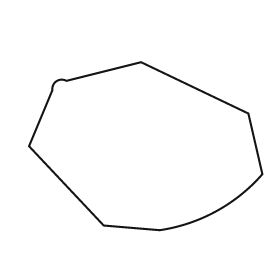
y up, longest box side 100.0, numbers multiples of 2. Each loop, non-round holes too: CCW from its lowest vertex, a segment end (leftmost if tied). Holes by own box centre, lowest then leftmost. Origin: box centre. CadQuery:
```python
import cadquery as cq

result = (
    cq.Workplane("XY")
    .moveTo(6.0, -36.0)
    .threePointArc((30.0, -28.0), (50.0, -12.0))
    .lineTo(44.0, 14.0)
    .lineTo(-2.0, 36.0)
    .lineTo(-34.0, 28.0)
    .threePointArc((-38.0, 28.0), (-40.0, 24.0))
    .lineTo(-50.0, 0.0)
    .lineTo(-18.0, -34.0)
    .close()
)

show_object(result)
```